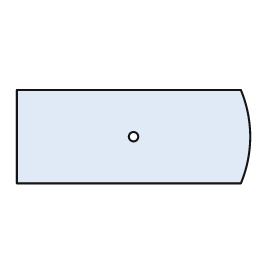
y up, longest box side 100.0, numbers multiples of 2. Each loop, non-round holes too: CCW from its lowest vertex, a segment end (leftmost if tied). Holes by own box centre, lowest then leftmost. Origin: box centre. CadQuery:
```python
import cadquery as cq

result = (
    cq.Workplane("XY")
    .moveTo(-50.0, -20.0)
    .lineTo(46.0, -20.0)
    .threePointArc((50.0, 0.0), (46.0, 20.0))
    .lineTo(-50.0, 20.0)
    .close()
    .moveTo(0.0, 0.0)
    .circle(2.0)
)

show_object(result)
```